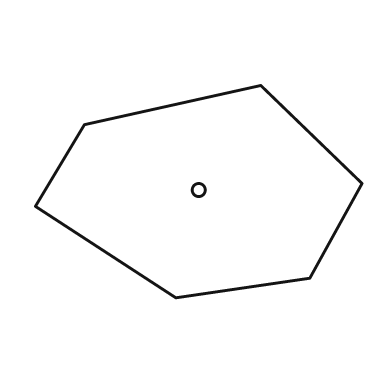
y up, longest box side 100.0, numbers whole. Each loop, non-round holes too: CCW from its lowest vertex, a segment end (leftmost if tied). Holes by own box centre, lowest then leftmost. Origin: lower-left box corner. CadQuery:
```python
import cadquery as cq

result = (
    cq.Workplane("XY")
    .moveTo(43.0, 0.0)
    .lineTo(84.0, 6.0)
    .lineTo(100.0, 35.0)
    .lineTo(69.0, 65.0)
    .lineTo(15.0, 53.0)
    .lineTo(0.0, 28.0)
    .close()
    .moveTo(50.0, 33.0)
    .circle(2.0)
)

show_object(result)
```